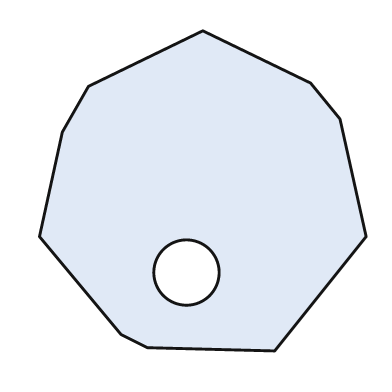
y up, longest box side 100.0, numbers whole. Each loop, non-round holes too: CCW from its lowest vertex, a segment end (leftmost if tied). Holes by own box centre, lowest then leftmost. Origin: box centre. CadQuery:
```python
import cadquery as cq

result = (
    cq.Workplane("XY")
    .moveTo(22.0, -49.0)
    .lineTo(50.0, -14.0)
    .lineTo(42.0, 22.0)
    .lineTo(33.0, 33.0)
    .lineTo(0.0, 49.0)
    .lineTo(-35.0, 32.0)
    .lineTo(-43.0, 18.0)
    .lineTo(-50.0, -14.0)
    .lineTo(-25.0, -44.0)
    .lineTo(-17.0, -48.0)
    .close()
    .moveTo(-5.0, -25.0)
    .circle(10.0)
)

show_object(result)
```